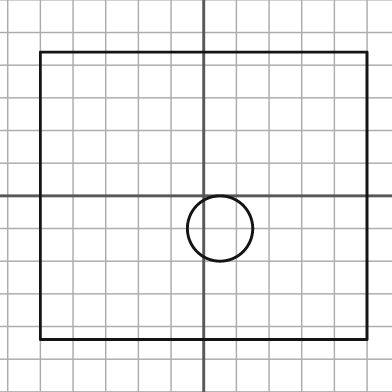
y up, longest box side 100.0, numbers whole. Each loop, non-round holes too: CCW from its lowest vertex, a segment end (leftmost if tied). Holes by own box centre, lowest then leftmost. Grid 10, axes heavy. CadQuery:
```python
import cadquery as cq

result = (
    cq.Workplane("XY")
    .moveTo(-50.0, -44.0)
    .lineTo(50.0, -44.0)
    .lineTo(50.0, 44.0)
    .lineTo(-50.0, 44.0)
    .close()
    .moveTo(5.0, -10.0)
    .circle(10.0)
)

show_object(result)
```